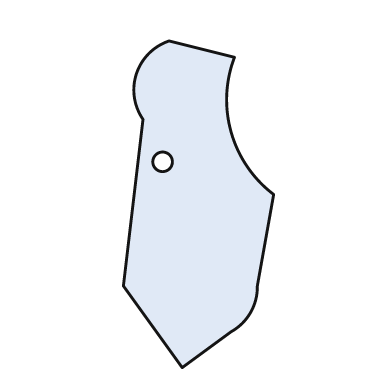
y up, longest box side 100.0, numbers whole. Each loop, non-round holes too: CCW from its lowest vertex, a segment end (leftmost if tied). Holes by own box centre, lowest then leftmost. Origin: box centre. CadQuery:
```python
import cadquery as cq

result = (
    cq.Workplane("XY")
    .moveTo(-5.0, -50.0)
    .lineTo(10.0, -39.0)
    .threePointArc((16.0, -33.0), (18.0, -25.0))
    .lineTo(23.0, 3.0)
    .threePointArc((10.0, 22.0), (11.0, 45.0))
    .lineTo(-9.0, 50.0)
    .threePointArc((-19.0, 40.0), (-17.0, 26.0))
    .lineTo(-23.0, -25.0)
    .close()
    .moveTo(-11.0, 13.0)
    .circle(3.0)
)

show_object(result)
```